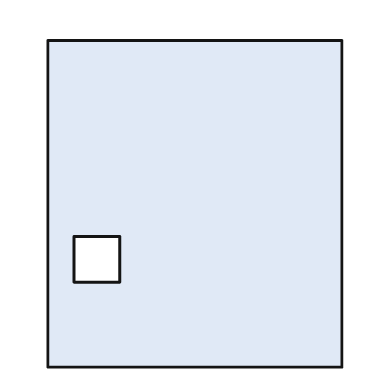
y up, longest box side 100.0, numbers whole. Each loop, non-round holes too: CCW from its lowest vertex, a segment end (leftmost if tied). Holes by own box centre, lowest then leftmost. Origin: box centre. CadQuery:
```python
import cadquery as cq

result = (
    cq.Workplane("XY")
    .moveTo(-45.0, -50.0)
    .lineTo(45.0, -50.0)
    .lineTo(45.0, 50.0)
    .lineTo(-45.0, 50.0)
    .close()
    .moveTo(-37.0, -24.0)
    .lineTo(-23.0, -24.0)
    .lineTo(-23.0, -10.0)
    .lineTo(-37.0, -10.0)
    .close()
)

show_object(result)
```